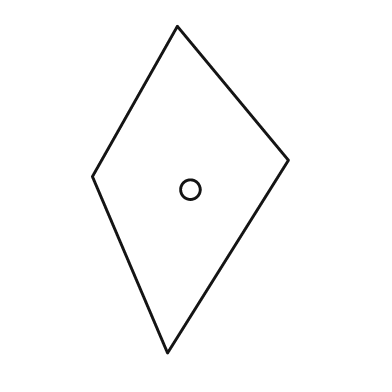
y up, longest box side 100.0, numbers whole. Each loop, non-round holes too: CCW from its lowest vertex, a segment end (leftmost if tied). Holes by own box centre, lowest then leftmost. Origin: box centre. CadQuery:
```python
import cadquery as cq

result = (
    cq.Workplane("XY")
    .moveTo(-7.0, -50.0)
    .lineTo(30.0, 9.0)
    .lineTo(-4.0, 50.0)
    .lineTo(-30.0, 4.0)
    .close()
    .moveTo(0.0, 0.0)
    .circle(3.0)
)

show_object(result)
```